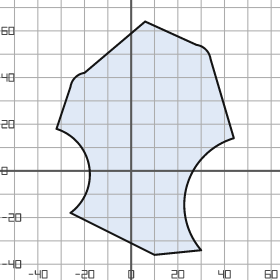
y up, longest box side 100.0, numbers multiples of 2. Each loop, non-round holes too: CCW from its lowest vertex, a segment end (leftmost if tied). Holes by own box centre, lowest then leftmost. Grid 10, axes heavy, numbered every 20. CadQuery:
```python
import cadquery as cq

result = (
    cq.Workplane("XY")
    .moveTo(10.0, -36.0)
    .lineTo(30.0, -34.0)
    .threePointArc((24.0, -6.0), (44.0, 14.0))
    .lineTo(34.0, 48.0)
    .threePointArc((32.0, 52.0), (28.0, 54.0))
    .lineTo(6.0, 64.0)
    .lineTo(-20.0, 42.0)
    .threePointArc((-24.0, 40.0), (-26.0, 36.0))
    .lineTo(-32.0, 18.0)
    .threePointArc((-18.0, 2.0), (-26.0, -18.0))
    .close()
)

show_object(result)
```